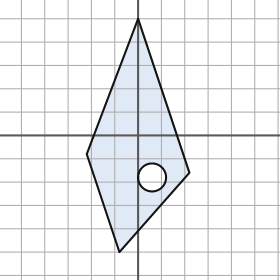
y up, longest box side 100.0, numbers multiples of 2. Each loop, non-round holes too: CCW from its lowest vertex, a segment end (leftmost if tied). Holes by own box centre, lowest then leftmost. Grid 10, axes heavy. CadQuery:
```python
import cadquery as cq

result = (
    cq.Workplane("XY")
    .moveTo(-8.0, -50.0)
    .lineTo(22.0, -16.0)
    .lineTo(0.0, 50.0)
    .lineTo(-22.0, -8.0)
    .close()
    .moveTo(6.0, -18.0)
    .circle(6.0)
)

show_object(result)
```